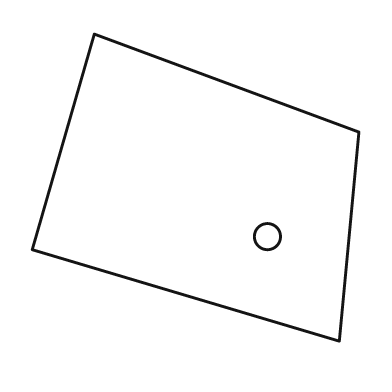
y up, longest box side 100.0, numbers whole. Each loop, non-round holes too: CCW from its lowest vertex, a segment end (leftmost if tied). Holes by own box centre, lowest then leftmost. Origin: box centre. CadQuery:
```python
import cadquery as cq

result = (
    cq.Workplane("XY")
    .moveTo(44.0, -47.0)
    .lineTo(50.0, 17.0)
    .lineTo(-31.0, 47.0)
    .lineTo(-50.0, -19.0)
    .close()
    .moveTo(22.0, -15.0)
    .circle(4.0)
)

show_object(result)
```